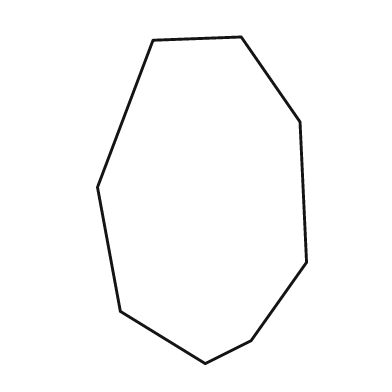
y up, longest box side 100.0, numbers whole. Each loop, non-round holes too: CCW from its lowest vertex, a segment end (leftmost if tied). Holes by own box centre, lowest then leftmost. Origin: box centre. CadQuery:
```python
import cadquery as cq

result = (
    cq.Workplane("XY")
    .moveTo(1.0, -50.0)
    .lineTo(15.0, -43.0)
    .lineTo(32.0, -19.0)
    .lineTo(30.0, 24.0)
    .lineTo(12.0, 50.0)
    .lineTo(-15.0, 49.0)
    .lineTo(-32.0, 4.0)
    .lineTo(-25.0, -34.0)
    .close()
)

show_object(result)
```